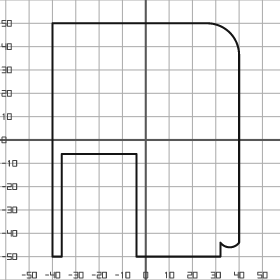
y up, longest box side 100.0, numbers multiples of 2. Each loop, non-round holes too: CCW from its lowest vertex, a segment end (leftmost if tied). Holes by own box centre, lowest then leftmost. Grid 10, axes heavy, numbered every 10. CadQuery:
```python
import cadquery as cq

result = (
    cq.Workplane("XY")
    .moveTo(-40.0, -50.0)
    .lineTo(-36.0, -50.0)
    .lineTo(-36.0, -6.0)
    .lineTo(-4.0, -6.0)
    .lineTo(-4.0, -50.0)
    .lineTo(32.0, -50.0)
    .lineTo(32.0, -44.0)
    .threePointArc((36.0, -46.0), (40.0, -44.0))
    .lineTo(40.0, 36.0)
    .threePointArc((36.0, 46.0), (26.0, 50.0))
    .lineTo(-40.0, 50.0)
    .close()
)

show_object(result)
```